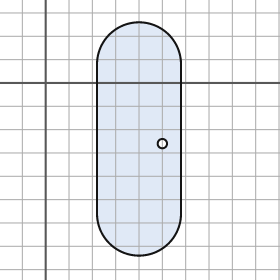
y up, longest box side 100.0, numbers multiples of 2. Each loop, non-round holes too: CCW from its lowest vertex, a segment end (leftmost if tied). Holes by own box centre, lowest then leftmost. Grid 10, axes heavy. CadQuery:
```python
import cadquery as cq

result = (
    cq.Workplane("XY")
    .moveTo(22.0, -56.0)
    .threePointArc((40.0, -74.0), (58.0, -56.0))
    .lineTo(58.0, 8.0)
    .threePointArc((40.0, 26.0), (22.0, 8.0))
    .close()
    .moveTo(50.0, -26.0)
    .circle(2.0)
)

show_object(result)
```